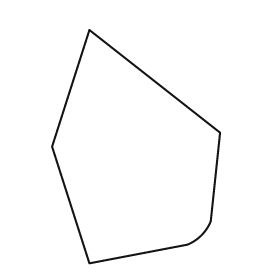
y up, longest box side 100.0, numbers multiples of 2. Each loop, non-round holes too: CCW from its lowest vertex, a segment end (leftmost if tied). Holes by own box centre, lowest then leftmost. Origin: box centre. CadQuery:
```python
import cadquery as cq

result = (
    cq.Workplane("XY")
    .moveTo(-20.0, -50.0)
    .lineTo(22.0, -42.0)
    .threePointArc((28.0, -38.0), (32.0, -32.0))
    .lineTo(36.0, 6.0)
    .lineTo(-20.0, 50.0)
    .lineTo(-36.0, 0.0)
    .close()
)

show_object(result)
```